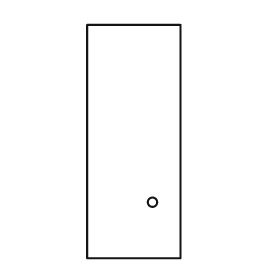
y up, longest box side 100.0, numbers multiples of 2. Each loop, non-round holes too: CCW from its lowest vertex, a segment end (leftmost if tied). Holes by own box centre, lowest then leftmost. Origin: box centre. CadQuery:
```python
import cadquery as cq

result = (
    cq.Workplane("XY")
    .moveTo(-20.0, -50.0)
    .lineTo(20.0, -50.0)
    .lineTo(20.0, 50.0)
    .lineTo(-20.0, 50.0)
    .close()
    .moveTo(8.0, -26.0)
    .circle(2.0)
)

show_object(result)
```